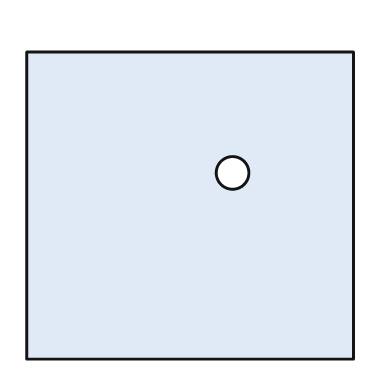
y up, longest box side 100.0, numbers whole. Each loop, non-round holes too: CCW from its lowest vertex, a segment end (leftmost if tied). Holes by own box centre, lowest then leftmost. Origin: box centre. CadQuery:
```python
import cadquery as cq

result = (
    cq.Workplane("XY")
    .moveTo(-50.0, -47.0)
    .lineTo(50.0, -47.0)
    .lineTo(50.0, 47.0)
    .lineTo(-50.0, 47.0)
    .close()
    .moveTo(13.0, 10.0)
    .circle(5.0)
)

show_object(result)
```